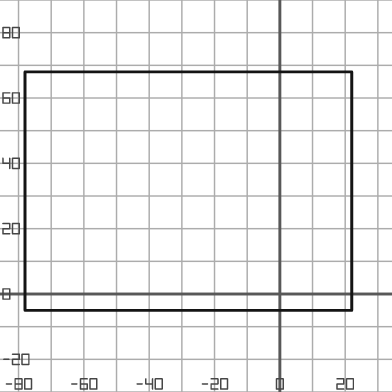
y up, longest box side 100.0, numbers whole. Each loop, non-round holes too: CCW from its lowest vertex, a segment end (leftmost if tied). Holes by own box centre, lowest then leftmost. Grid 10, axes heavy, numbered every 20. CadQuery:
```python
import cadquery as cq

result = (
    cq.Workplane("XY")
    .moveTo(-78.0, -5.0)
    .lineTo(22.0, -5.0)
    .lineTo(22.0, 68.0)
    .lineTo(-78.0, 68.0)
    .close()
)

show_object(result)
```